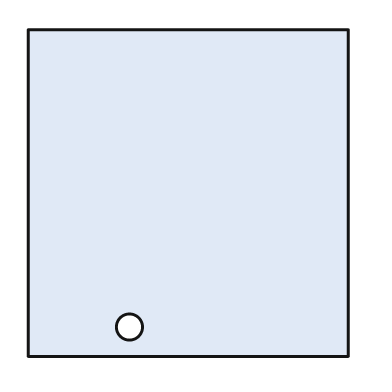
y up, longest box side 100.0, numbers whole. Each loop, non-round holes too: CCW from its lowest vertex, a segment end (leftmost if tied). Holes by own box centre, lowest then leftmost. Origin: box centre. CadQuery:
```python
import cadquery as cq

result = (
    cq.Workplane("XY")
    .moveTo(-49.0, -50.0)
    .lineTo(49.0, -50.0)
    .lineTo(49.0, 50.0)
    .lineTo(-49.0, 50.0)
    .close()
    .moveTo(-18.0, -41.0)
    .circle(4.0)
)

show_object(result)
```